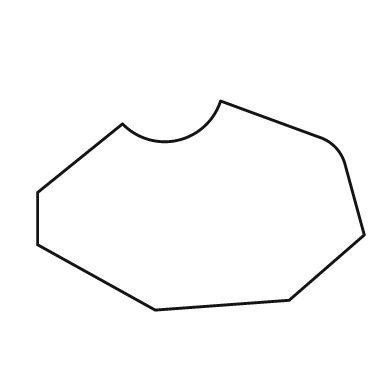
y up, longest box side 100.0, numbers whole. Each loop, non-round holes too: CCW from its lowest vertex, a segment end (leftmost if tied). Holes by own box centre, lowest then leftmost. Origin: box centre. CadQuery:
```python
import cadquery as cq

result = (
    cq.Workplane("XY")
    .moveTo(-14.0, -32.0)
    .lineTo(27.0, -29.0)
    .lineTo(50.0, -9.0)
    .lineTo(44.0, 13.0)
    .threePointArc((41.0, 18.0), (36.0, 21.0))
    .lineTo(6.0, 32.0)
    .threePointArc((-7.0, 20.0), (-24.0, 25.0))
    .lineTo(-50.0, 4.0)
    .lineTo(-50.0, -12.0)
    .close()
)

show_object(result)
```